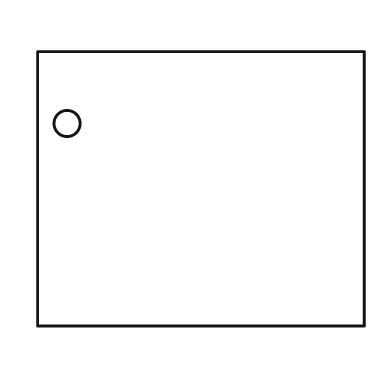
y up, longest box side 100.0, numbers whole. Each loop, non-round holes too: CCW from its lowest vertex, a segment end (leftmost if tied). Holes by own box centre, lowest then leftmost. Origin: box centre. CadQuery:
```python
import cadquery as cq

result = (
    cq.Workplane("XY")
    .moveTo(-50.0, -42.0)
    .lineTo(50.0, -42.0)
    .lineTo(50.0, 42.0)
    .lineTo(-50.0, 42.0)
    .close()
    .moveTo(-41.0, 20.0)
    .circle(4.0)
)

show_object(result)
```